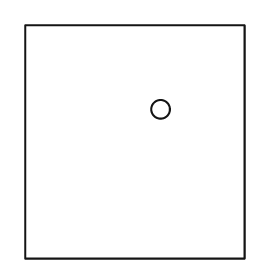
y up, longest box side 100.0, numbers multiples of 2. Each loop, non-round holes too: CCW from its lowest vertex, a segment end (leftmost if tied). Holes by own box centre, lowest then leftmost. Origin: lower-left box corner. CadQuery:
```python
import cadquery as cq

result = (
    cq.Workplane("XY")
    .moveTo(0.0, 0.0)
    .lineTo(94.0, 0.0)
    .lineTo(94.0, 100.0)
    .lineTo(0.0, 100.0)
    .close()
    .moveTo(58.0, 64.0)
    .circle(4.0)
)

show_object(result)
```